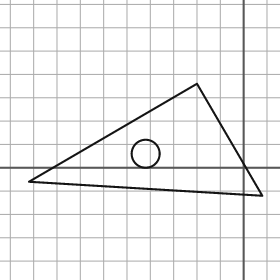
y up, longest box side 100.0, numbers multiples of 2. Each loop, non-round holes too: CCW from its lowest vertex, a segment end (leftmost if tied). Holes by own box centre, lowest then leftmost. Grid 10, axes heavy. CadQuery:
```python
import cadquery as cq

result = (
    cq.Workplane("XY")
    .moveTo(8.0, -12.0)
    .lineTo(-20.0, 36.0)
    .lineTo(-92.0, -6.0)
    .close()
    .moveTo(-42.0, 6.0)
    .circle(6.0)
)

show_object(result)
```